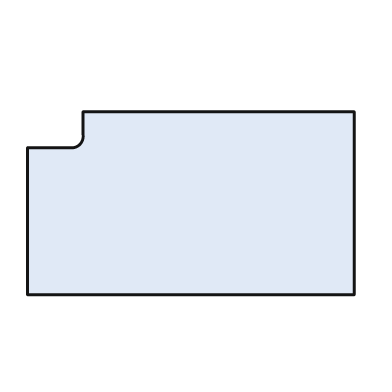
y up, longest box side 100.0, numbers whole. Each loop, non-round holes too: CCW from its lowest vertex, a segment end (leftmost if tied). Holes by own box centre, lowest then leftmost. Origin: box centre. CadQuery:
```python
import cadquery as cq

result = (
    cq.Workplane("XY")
    .moveTo(-50.0, -28.0)
    .lineTo(50.0, -28.0)
    .lineTo(50.0, 28.0)
    .lineTo(-33.0, 28.0)
    .lineTo(-33.0, 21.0)
    .threePointArc((-34.0, 18.0), (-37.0, 17.0))
    .lineTo(-50.0, 17.0)
    .close()
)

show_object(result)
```